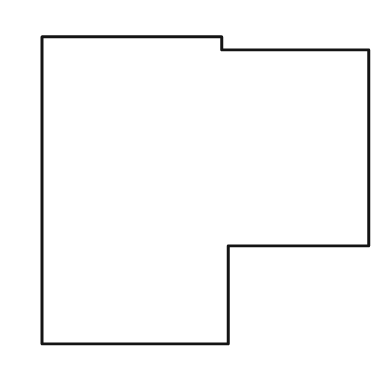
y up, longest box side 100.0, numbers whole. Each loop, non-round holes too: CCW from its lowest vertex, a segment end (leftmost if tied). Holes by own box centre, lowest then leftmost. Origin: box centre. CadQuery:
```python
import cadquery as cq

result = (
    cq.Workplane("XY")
    .moveTo(-50.0, -47.0)
    .lineTo(7.0, -47.0)
    .lineTo(7.0, -17.0)
    .lineTo(50.0, -17.0)
    .lineTo(50.0, 43.0)
    .lineTo(5.0, 43.0)
    .lineTo(5.0, 47.0)
    .lineTo(-50.0, 47.0)
    .close()
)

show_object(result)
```